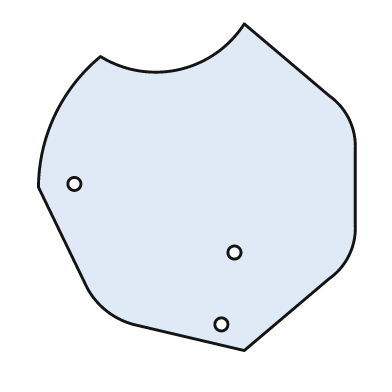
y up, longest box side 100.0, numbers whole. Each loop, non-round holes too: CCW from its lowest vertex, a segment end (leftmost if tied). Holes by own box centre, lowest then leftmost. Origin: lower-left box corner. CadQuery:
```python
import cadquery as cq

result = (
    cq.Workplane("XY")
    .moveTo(63.0, 0.0)
    .lineTo(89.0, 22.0)
    .threePointArc((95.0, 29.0), (97.0, 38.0))
    .lineTo(97.0, 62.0)
    .threePointArc((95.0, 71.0), (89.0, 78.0))
    .lineTo(63.0, 100.0)
    .threePointArc((43.0, 86.0), (19.0, 90.0))
    .threePointArc((5.0, 72.0), (0.0, 50.0))
    .lineTo(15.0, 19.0)
    .threePointArc((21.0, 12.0), (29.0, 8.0))
    .close()
    .moveTo(56.0, 8.0)
    .circle(2.0)
    .moveTo(60.0, 30.0)
    .circle(2.0)
    .moveTo(11.0, 51.0)
    .circle(2.0)
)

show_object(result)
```